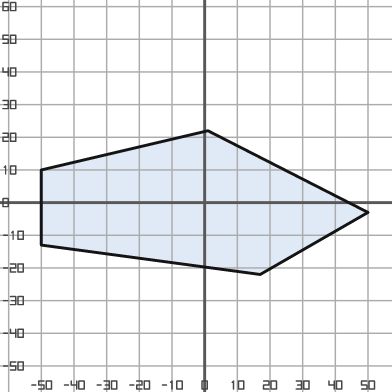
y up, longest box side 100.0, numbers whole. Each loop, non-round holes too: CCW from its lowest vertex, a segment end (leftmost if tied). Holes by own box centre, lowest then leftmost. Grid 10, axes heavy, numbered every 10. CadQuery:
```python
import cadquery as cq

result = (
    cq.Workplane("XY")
    .moveTo(17.0, -22.0)
    .lineTo(50.0, -3.0)
    .lineTo(1.0, 22.0)
    .lineTo(-50.0, 10.0)
    .lineTo(-50.0, -13.0)
    .close()
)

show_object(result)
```